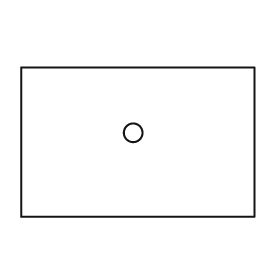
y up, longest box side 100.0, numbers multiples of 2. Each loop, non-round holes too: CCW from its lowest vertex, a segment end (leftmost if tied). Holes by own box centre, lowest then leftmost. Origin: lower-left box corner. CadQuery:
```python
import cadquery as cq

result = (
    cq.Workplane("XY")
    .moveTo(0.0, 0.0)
    .lineTo(100.0, 0.0)
    .lineTo(100.0, 64.0)
    .lineTo(0.0, 64.0)
    .close()
    .moveTo(48.0, 36.0)
    .circle(4.0)
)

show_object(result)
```